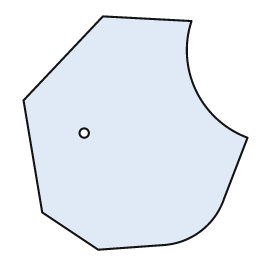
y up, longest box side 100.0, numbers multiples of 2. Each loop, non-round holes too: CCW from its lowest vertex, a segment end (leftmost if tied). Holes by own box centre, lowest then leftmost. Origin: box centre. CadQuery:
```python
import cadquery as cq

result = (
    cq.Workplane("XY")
    .moveTo(-16.0, -50.0)
    .lineTo(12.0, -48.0)
    .threePointArc((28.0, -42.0), (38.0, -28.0))
    .lineTo(48.0, -2.0)
    .threePointArc((26.0, 18.0), (24.0, 48.0))
    .lineTo(-14.0, 50.0)
    .lineTo(-48.0, 14.0)
    .lineTo(-40.0, -34.0)
    .close()
    .moveTo(-22.0, 0.0)
    .circle(2.0)
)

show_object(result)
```